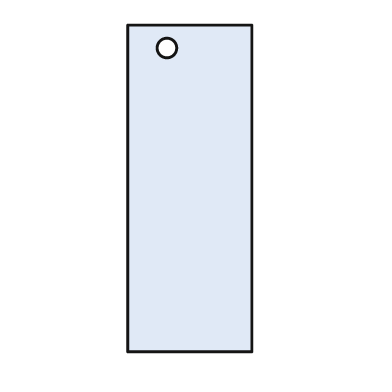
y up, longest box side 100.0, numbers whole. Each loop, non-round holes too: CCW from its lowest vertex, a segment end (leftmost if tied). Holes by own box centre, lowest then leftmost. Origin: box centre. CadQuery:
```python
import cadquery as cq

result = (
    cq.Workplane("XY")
    .moveTo(-19.0, -50.0)
    .lineTo(19.0, -50.0)
    .lineTo(19.0, 50.0)
    .lineTo(-19.0, 50.0)
    .close()
    .moveTo(-7.0, 43.0)
    .circle(3.0)
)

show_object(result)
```